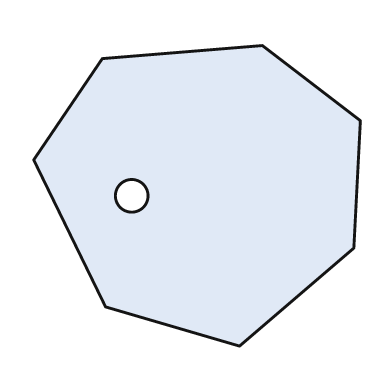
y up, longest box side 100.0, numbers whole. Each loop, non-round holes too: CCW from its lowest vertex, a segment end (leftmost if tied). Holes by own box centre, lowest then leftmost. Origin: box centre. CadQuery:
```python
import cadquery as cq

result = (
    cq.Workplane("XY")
    .moveTo(13.0, -46.0)
    .lineTo(48.0, -16.0)
    .lineTo(50.0, 23.0)
    .lineTo(20.0, 46.0)
    .lineTo(-29.0, 42.0)
    .lineTo(-50.0, 11.0)
    .lineTo(-28.0, -34.0)
    .close()
    .moveTo(-20.0, 0.0)
    .circle(5.0)
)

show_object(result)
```